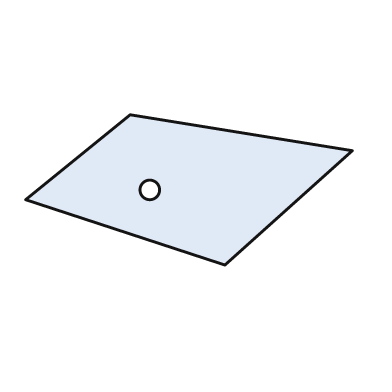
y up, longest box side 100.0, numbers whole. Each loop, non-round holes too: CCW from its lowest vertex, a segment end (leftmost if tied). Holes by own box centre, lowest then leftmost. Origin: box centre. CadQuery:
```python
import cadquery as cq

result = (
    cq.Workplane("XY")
    .moveTo(11.0, -23.0)
    .lineTo(50.0, 12.0)
    .lineTo(-18.0, 23.0)
    .lineTo(-50.0, -3.0)
    .close()
    .moveTo(-12.0, 0.0)
    .circle(3.0)
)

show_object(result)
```